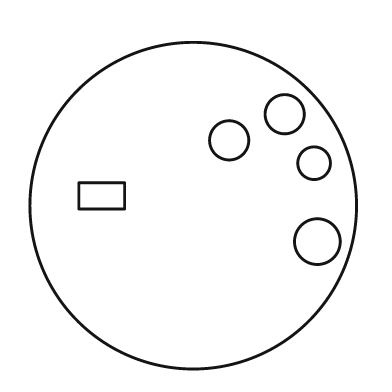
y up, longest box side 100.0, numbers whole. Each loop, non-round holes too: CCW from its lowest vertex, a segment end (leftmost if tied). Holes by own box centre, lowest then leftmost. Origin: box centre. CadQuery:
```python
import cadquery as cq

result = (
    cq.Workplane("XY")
    .moveTo(0.0, 0.0)
    .circle(50.0)
    .moveTo(38.0, -11.0)
    .circle(7.0)
    .moveTo(-35.0, -1.0)
    .lineTo(-21.0, -1.0)
    .lineTo(-21.0, 7.0)
    .lineTo(-35.0, 7.0)
    .close()
    .moveTo(37.0, 13.0)
    .circle(5.0)
    .moveTo(11.0, 20.0)
    .circle(6.0)
    .moveTo(28.0, 28.0)
    .circle(6.0)
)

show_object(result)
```